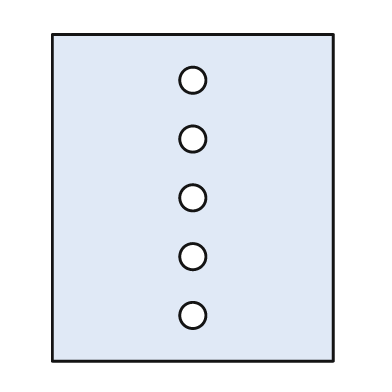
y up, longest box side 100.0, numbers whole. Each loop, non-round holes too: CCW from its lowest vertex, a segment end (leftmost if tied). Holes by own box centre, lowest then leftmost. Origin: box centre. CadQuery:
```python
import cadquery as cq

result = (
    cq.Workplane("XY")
    .moveTo(-43.0, -50.0)
    .lineTo(43.0, -50.0)
    .lineTo(43.0, 50.0)
    .lineTo(-43.0, 50.0)
    .close()
    .moveTo(0.0, -36.0)
    .circle(4.0)
    .moveTo(0.0, -18.0)
    .circle(4.0)
    .moveTo(0.0, 0.0)
    .circle(4.0)
    .moveTo(0.0, 18.0)
    .circle(4.0)
    .moveTo(0.0, 36.0)
    .circle(4.0)
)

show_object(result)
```